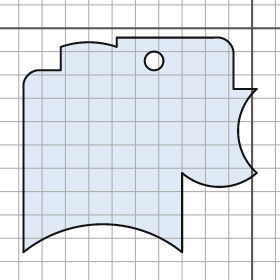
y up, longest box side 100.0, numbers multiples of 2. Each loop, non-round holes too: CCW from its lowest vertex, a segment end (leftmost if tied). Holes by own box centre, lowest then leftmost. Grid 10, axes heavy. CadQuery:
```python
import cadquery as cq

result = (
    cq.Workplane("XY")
    .moveTo(-98.0, -96.0)
    .threePointArc((-64.0, -84.0), (-30.0, -96.0))
    .lineTo(-30.0, -62.0)
    .threePointArc((-14.0, -68.0), (2.0, -62.0))
    .threePointArc((-6.0, -44.0), (2.0, -26.0))
    .lineTo(-8.0, -26.0)
    .lineTo(-8.0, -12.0)
    .threePointArc((-10.0, -6.0), (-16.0, -4.0))
    .lineTo(-58.0, -4.0)
    .lineTo(-58.0, -8.0)
    .threePointArc((-70.0, -6.0), (-82.0, -8.0))
    .lineTo(-82.0, -18.0)
    .lineTo(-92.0, -18.0)
    .threePointArc((-96.0, -20.0), (-98.0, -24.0))
    .close()
    .moveTo(-42.0, -14.0)
    .circle(4.0)
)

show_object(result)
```